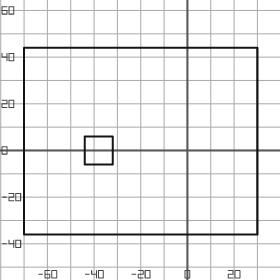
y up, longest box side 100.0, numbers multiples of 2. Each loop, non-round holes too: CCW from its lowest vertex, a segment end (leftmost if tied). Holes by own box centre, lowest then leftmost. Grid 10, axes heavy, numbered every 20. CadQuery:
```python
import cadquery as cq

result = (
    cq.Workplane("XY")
    .moveTo(-70.0, -36.0)
    .lineTo(30.0, -36.0)
    .lineTo(30.0, 44.0)
    .lineTo(-70.0, 44.0)
    .close()
    .moveTo(-44.0, -6.0)
    .lineTo(-32.0, -6.0)
    .lineTo(-32.0, 6.0)
    .lineTo(-44.0, 6.0)
    .close()
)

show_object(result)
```